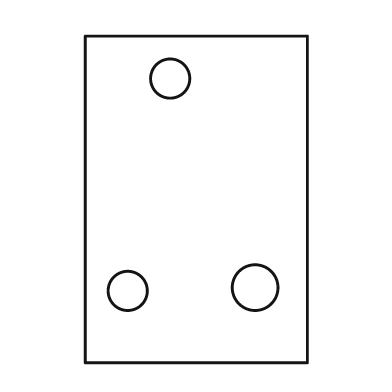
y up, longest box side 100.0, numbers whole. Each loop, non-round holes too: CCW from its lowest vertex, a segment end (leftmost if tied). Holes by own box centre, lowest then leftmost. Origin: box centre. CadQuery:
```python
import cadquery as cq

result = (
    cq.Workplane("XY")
    .moveTo(-34.0, -50.0)
    .lineTo(34.0, -50.0)
    .lineTo(34.0, 50.0)
    .lineTo(-34.0, 50.0)
    .close()
    .moveTo(-21.0, -28.0)
    .circle(6.0)
    .moveTo(18.0, -27.0)
    .circle(7.0)
    .moveTo(-8.0, 37.0)
    .circle(6.0)
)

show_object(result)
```